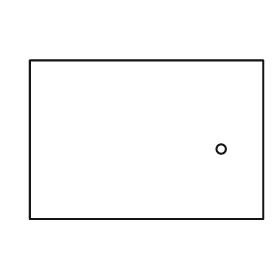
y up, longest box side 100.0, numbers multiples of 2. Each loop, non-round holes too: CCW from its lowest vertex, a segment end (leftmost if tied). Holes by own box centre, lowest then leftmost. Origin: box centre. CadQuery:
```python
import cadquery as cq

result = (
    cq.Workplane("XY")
    .moveTo(-50.0, -34.0)
    .lineTo(50.0, -34.0)
    .lineTo(50.0, 34.0)
    .lineTo(-50.0, 34.0)
    .close()
    .moveTo(32.0, -4.0)
    .circle(2.0)
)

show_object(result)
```